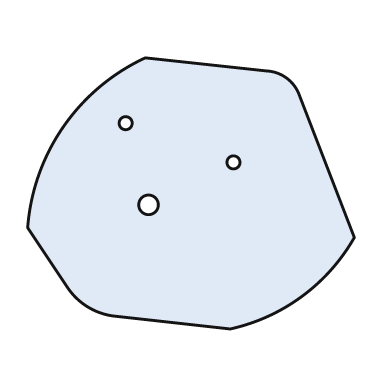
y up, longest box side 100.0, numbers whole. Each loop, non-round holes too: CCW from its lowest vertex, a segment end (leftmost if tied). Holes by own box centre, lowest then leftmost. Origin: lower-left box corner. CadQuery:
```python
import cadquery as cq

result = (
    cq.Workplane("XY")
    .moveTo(62.0, 0.0)
    .threePointArc((84.0, 10.0), (100.0, 28.0))
    .lineTo(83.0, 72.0)
    .threePointArc((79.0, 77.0), (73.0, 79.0))
    .lineTo(36.0, 83.0)
    .threePointArc((11.0, 62.0), (0.0, 31.0))
    .lineTo(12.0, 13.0)
    .threePointArc((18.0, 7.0), (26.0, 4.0))
    .close()
    .moveTo(37.0, 38.0)
    .circle(3.0)
    .moveTo(63.0, 51.0)
    .circle(2.0)
    .moveTo(30.0, 63.0)
    .circle(2.0)
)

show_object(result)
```